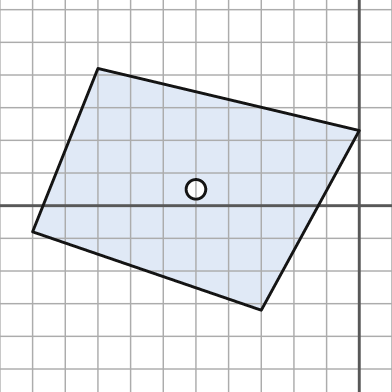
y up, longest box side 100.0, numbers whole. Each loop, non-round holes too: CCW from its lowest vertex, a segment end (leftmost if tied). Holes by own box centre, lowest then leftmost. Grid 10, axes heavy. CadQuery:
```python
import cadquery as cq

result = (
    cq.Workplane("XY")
    .moveTo(-30.0, -32.0)
    .lineTo(0.0, 23.0)
    .lineTo(-80.0, 42.0)
    .lineTo(-100.0, -8.0)
    .close()
    .moveTo(-50.0, 5.0)
    .circle(3.0)
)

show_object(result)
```